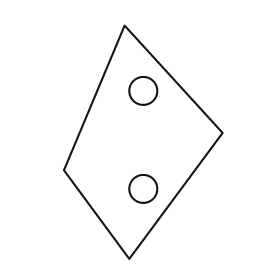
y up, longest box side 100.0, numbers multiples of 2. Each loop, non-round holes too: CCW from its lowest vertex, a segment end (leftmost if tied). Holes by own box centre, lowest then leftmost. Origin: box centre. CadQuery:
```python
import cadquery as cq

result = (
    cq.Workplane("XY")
    .moveTo(-6.0, -50.0)
    .lineTo(34.0, 4.0)
    .lineTo(-8.0, 50.0)
    .lineTo(-34.0, -12.0)
    .close()
    .moveTo(0.0, -20.0)
    .circle(6.0)
    .moveTo(0.0, 22.0)
    .circle(6.0)
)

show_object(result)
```